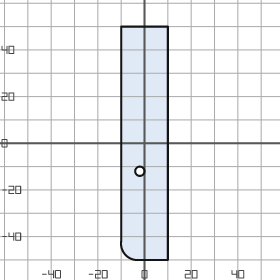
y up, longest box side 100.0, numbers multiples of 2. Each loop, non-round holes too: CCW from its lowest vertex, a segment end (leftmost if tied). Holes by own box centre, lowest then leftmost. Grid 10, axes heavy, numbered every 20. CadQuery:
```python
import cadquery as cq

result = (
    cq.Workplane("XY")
    .moveTo(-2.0, -50.0)
    .lineTo(10.0, -50.0)
    .lineTo(10.0, 50.0)
    .lineTo(-10.0, 50.0)
    .lineTo(-10.0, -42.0)
    .threePointArc((-8.0, -48.0), (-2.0, -50.0))
    .close()
    .moveTo(-2.0, -12.0)
    .circle(2.0)
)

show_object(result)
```